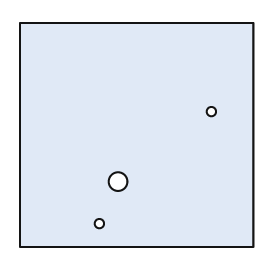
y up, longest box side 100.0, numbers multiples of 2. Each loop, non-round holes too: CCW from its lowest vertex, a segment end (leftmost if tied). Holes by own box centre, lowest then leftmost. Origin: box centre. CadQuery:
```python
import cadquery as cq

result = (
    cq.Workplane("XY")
    .moveTo(-50.0, -48.0)
    .lineTo(50.0, -48.0)
    .lineTo(50.0, 48.0)
    .lineTo(-50.0, 48.0)
    .close()
    .moveTo(-16.0, -38.0)
    .circle(2.0)
    .moveTo(-8.0, -20.0)
    .circle(4.0)
    .moveTo(32.0, 10.0)
    .circle(2.0)
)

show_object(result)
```